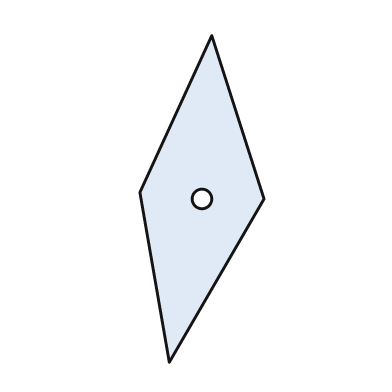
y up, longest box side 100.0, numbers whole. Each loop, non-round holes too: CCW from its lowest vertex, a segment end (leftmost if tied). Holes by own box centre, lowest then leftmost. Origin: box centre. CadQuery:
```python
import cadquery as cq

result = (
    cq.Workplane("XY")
    .moveTo(-10.0, -50.0)
    .lineTo(19.0, 0.0)
    .lineTo(3.0, 50.0)
    .lineTo(-19.0, 2.0)
    .close()
    .moveTo(0.0, 0.0)
    .circle(3.0)
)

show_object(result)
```